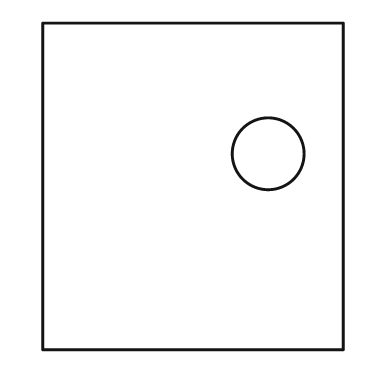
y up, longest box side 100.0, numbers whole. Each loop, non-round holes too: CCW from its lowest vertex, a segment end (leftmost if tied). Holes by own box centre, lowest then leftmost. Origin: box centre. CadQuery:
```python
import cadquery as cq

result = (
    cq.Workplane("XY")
    .moveTo(-46.0, -50.0)
    .lineTo(46.0, -50.0)
    .lineTo(46.0, 50.0)
    .lineTo(-46.0, 50.0)
    .close()
    .moveTo(23.0, 10.0)
    .circle(11.0)
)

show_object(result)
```